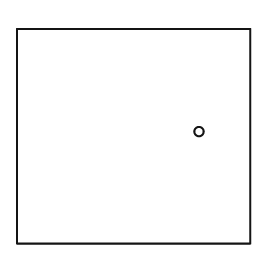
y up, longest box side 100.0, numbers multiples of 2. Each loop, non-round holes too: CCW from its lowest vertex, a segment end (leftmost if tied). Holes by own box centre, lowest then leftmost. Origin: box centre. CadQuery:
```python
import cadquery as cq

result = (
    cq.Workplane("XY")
    .moveTo(-50.0, -46.0)
    .lineTo(50.0, -46.0)
    .lineTo(50.0, 46.0)
    .lineTo(-50.0, 46.0)
    .close()
    .moveTo(28.0, 2.0)
    .circle(2.0)
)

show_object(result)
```